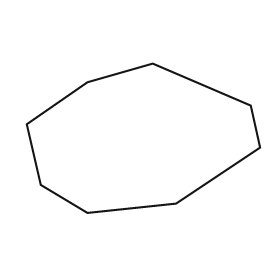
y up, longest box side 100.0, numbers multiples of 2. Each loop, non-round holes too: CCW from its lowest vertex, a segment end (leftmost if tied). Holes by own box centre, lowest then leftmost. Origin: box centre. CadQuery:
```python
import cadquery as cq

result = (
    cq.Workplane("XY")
    .moveTo(-24.0, -32.0)
    .lineTo(14.0, -28.0)
    .lineTo(50.0, -4.0)
    .lineTo(46.0, 14.0)
    .lineTo(4.0, 32.0)
    .lineTo(-24.0, 24.0)
    .lineTo(-50.0, 6.0)
    .lineTo(-44.0, -20.0)
    .close()
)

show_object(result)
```